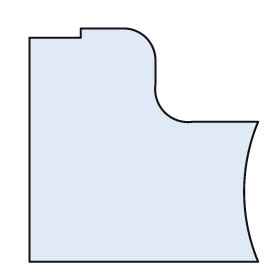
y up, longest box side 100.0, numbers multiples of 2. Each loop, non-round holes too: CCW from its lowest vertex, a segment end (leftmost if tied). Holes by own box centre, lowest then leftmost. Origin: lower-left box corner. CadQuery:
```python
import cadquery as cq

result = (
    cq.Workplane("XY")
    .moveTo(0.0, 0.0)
    .lineTo(98.0, 0.0)
    .threePointArc((92.0, 30.0), (98.0, 60.0))
    .lineTo(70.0, 60.0)
    .threePointArc((58.0, 64.0), (54.0, 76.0))
    .lineTo(54.0, 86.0)
    .threePointArc((50.0, 96.0), (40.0, 100.0))
    .lineTo(22.0, 100.0)
    .lineTo(22.0, 96.0)
    .lineTo(0.0, 96.0)
    .close()
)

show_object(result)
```